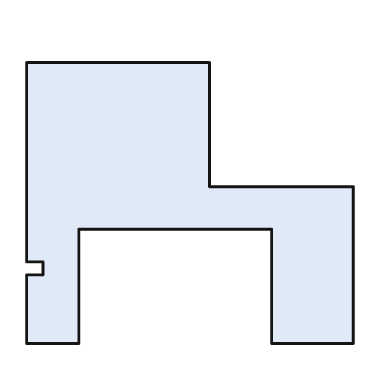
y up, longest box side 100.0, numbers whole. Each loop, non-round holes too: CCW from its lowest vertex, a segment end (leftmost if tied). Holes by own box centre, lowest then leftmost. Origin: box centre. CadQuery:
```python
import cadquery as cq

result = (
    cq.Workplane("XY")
    .moveTo(-50.0, -43.0)
    .lineTo(-34.0, -43.0)
    .lineTo(-34.0, -8.0)
    .lineTo(25.0, -8.0)
    .lineTo(25.0, -43.0)
    .lineTo(50.0, -43.0)
    .lineTo(50.0, 5.0)
    .lineTo(6.0, 5.0)
    .lineTo(6.0, 43.0)
    .lineTo(-50.0, 43.0)
    .lineTo(-50.0, -18.0)
    .lineTo(-45.0, -18.0)
    .lineTo(-45.0, -22.0)
    .lineTo(-50.0, -22.0)
    .close()
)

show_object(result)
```